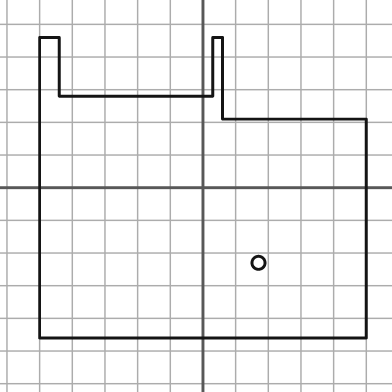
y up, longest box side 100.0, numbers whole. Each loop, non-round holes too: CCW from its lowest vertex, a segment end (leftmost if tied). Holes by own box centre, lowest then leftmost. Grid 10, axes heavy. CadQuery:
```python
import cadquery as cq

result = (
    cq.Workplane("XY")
    .moveTo(-50.0, -46.0)
    .lineTo(50.0, -46.0)
    .lineTo(50.0, 21.0)
    .lineTo(6.0, 21.0)
    .lineTo(6.0, 46.0)
    .lineTo(3.0, 46.0)
    .lineTo(3.0, 28.0)
    .lineTo(-44.0, 28.0)
    .lineTo(-44.0, 46.0)
    .lineTo(-50.0, 46.0)
    .close()
    .moveTo(17.0, -23.0)
    .circle(2.0)
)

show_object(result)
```